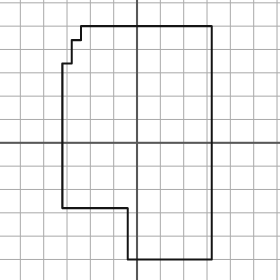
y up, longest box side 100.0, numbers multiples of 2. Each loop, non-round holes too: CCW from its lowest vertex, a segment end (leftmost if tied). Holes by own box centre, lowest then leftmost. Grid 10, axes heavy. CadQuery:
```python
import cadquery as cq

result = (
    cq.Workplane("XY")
    .moveTo(-4.0, -50.0)
    .lineTo(32.0, -50.0)
    .lineTo(32.0, 50.0)
    .lineTo(-24.0, 50.0)
    .lineTo(-24.0, 44.0)
    .lineTo(-28.0, 44.0)
    .lineTo(-28.0, 34.0)
    .lineTo(-32.0, 34.0)
    .lineTo(-32.0, -28.0)
    .lineTo(-4.0, -28.0)
    .close()
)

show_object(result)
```